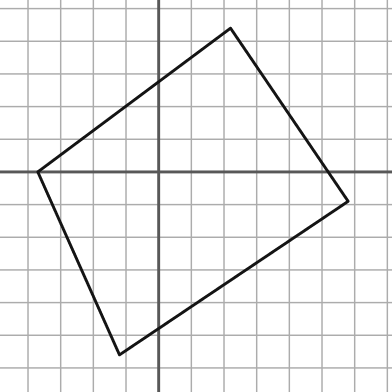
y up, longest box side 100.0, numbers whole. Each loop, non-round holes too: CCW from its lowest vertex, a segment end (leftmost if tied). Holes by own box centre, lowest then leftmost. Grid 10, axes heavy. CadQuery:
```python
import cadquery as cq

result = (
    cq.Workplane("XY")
    .moveTo(-12.0, -56.0)
    .lineTo(58.0, -9.0)
    .lineTo(22.0, 44.0)
    .lineTo(-37.0, 0.0)
    .close()
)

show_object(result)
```